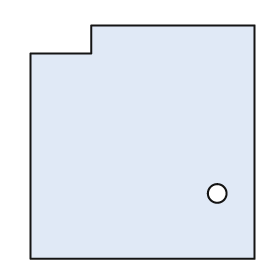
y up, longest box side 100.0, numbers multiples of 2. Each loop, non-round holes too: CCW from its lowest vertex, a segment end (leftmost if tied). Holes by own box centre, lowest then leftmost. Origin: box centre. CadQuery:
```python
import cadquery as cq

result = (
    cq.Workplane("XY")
    .moveTo(-48.0, -50.0)
    .lineTo(48.0, -50.0)
    .lineTo(48.0, 50.0)
    .lineTo(-22.0, 50.0)
    .lineTo(-22.0, 38.0)
    .lineTo(-48.0, 38.0)
    .close()
    .moveTo(32.0, -22.0)
    .circle(4.0)
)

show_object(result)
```